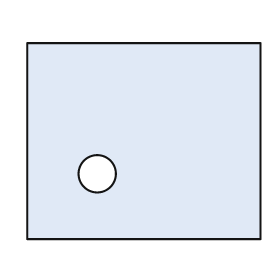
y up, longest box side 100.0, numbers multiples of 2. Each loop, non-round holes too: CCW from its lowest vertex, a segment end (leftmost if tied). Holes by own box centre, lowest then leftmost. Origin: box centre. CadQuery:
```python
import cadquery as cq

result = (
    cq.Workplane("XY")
    .moveTo(-50.0, -42.0)
    .lineTo(50.0, -42.0)
    .lineTo(50.0, 42.0)
    .lineTo(-50.0, 42.0)
    .close()
    .moveTo(-20.0, -14.0)
    .circle(8.0)
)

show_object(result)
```